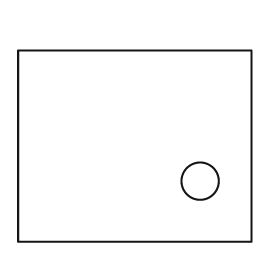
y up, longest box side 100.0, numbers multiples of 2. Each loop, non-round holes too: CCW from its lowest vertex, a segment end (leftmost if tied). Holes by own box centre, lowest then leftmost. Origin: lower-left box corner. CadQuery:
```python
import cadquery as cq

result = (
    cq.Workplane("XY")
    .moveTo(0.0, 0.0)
    .lineTo(100.0, 0.0)
    .lineTo(100.0, 82.0)
    .lineTo(0.0, 82.0)
    .close()
    .moveTo(78.0, 26.0)
    .circle(8.0)
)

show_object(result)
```